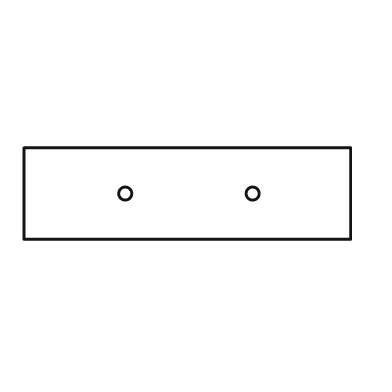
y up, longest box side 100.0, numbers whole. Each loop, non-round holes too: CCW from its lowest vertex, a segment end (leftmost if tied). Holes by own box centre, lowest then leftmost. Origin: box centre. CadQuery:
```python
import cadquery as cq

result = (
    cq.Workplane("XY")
    .moveTo(-50.0, -14.0)
    .lineTo(50.0, -14.0)
    .lineTo(50.0, 14.0)
    .lineTo(-50.0, 14.0)
    .close()
    .moveTo(-19.0, 0.0)
    .circle(2.0)
    .moveTo(20.0, 0.0)
    .circle(2.0)
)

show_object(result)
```